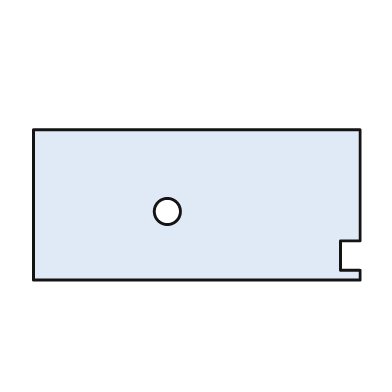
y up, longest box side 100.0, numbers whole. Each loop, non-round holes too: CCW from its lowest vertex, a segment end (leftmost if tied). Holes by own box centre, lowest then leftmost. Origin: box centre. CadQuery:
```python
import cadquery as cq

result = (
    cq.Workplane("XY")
    .moveTo(-50.0, -23.0)
    .lineTo(50.0, -23.0)
    .lineTo(50.0, -20.0)
    .lineTo(44.0, -20.0)
    .lineTo(44.0, -11.0)
    .lineTo(50.0, -11.0)
    .lineTo(50.0, 23.0)
    .lineTo(-50.0, 23.0)
    .close()
    .moveTo(-9.0, -2.0)
    .circle(4.0)
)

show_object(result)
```